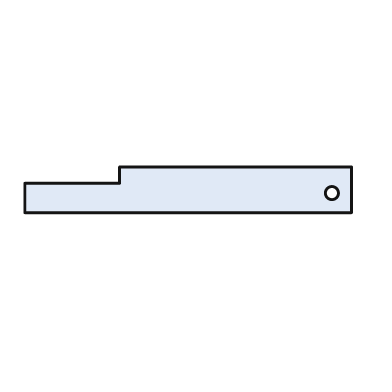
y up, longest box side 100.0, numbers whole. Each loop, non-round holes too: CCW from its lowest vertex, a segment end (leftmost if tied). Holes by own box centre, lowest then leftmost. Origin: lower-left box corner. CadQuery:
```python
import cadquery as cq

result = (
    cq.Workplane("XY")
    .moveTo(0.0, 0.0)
    .lineTo(100.0, 0.0)
    .lineTo(100.0, 14.0)
    .lineTo(29.0, 14.0)
    .lineTo(29.0, 9.0)
    .lineTo(0.0, 9.0)
    .close()
    .moveTo(94.0, 6.0)
    .circle(2.0)
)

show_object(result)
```